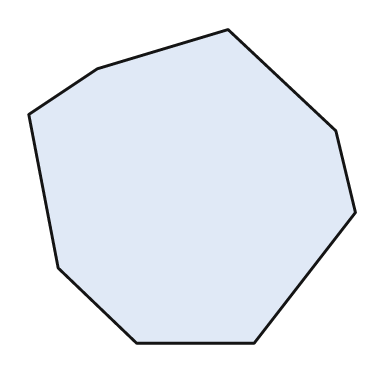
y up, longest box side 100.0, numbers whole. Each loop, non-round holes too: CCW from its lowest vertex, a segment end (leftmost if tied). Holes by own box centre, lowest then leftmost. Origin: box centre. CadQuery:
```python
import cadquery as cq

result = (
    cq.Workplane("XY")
    .moveTo(-17.0, -48.0)
    .lineTo(19.0, -48.0)
    .lineTo(50.0, -8.0)
    .lineTo(44.0, 17.0)
    .lineTo(11.0, 48.0)
    .lineTo(-29.0, 36.0)
    .lineTo(-50.0, 22.0)
    .lineTo(-41.0, -25.0)
    .close()
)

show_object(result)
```